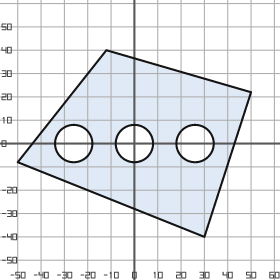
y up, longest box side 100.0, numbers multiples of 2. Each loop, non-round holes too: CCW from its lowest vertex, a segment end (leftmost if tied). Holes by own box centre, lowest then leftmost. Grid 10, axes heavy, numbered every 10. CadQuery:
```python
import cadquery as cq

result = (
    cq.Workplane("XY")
    .moveTo(30.0, -40.0)
    .lineTo(50.0, 22.0)
    .lineTo(-12.0, 40.0)
    .lineTo(-50.0, -8.0)
    .close()
    .moveTo(-26.0, 0.0)
    .circle(8.0)
    .moveTo(0.0, 0.0)
    .circle(8.0)
    .moveTo(26.0, 0.0)
    .circle(8.0)
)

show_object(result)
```